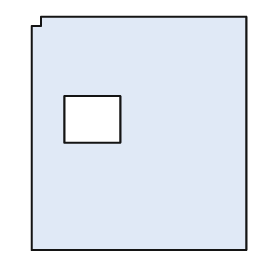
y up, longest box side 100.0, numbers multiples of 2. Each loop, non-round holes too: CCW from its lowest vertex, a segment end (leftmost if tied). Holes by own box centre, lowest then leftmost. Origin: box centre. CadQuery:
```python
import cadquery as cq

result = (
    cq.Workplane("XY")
    .moveTo(-46.0, -50.0)
    .lineTo(46.0, -50.0)
    .lineTo(46.0, 50.0)
    .lineTo(-42.0, 50.0)
    .lineTo(-42.0, 46.0)
    .lineTo(-46.0, 46.0)
    .close()
    .moveTo(-32.0, -4.0)
    .lineTo(-8.0, -4.0)
    .lineTo(-8.0, 16.0)
    .lineTo(-32.0, 16.0)
    .close()
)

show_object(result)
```